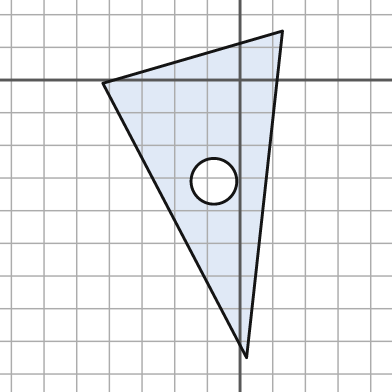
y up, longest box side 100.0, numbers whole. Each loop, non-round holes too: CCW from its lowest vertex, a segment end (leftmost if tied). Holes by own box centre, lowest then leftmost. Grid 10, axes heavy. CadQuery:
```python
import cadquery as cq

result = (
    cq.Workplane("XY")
    .moveTo(2.0, -85.0)
    .lineTo(13.0, 15.0)
    .lineTo(-42.0, -1.0)
    .close()
    .moveTo(-8.0, -31.0)
    .circle(7.0)
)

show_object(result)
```